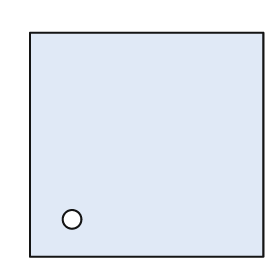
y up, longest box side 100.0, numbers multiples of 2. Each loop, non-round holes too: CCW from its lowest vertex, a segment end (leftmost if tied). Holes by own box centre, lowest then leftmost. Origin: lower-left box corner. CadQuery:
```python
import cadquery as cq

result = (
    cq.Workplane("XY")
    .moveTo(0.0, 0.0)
    .lineTo(100.0, 0.0)
    .lineTo(100.0, 96.0)
    .lineTo(0.0, 96.0)
    .close()
    .moveTo(18.0, 16.0)
    .circle(4.0)
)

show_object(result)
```